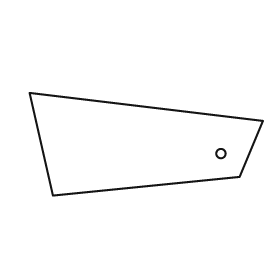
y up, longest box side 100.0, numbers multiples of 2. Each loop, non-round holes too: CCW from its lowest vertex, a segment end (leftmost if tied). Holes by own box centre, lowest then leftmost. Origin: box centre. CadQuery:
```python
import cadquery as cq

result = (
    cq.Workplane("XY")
    .moveTo(-40.0, -22.0)
    .lineTo(40.0, -14.0)
    .lineTo(50.0, 10.0)
    .lineTo(-50.0, 22.0)
    .close()
    .moveTo(32.0, -4.0)
    .circle(2.0)
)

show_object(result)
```